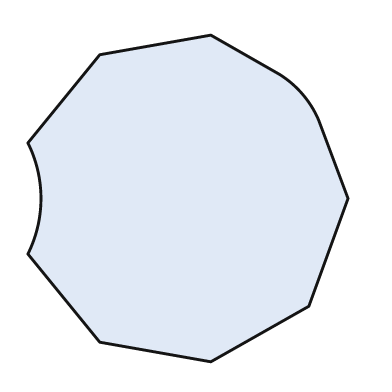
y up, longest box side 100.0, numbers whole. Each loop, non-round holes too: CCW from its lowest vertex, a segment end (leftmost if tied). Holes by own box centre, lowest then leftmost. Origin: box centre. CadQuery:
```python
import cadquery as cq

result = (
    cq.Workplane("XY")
    .moveTo(7.0, -50.0)
    .lineTo(37.0, -33.0)
    .lineTo(49.0, 0.0)
    .lineTo(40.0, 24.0)
    .threePointArc((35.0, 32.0), (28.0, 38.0))
    .lineTo(7.0, 50.0)
    .lineTo(-27.0, 44.0)
    .lineTo(-49.0, 17.0)
    .threePointArc((-45.0, 0.0), (-49.0, -17.0))
    .lineTo(-27.0, -44.0)
    .close()
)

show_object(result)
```